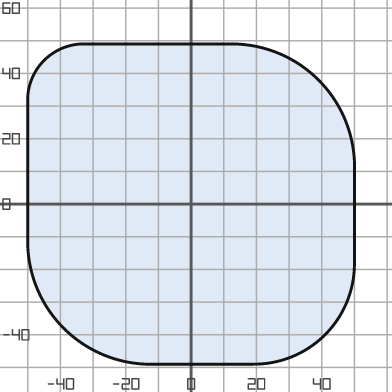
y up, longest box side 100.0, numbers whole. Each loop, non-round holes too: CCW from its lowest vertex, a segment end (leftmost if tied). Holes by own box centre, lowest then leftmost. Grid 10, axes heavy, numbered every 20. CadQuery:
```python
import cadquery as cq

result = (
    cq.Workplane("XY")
    .moveTo(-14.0, -49.0)
    .lineTo(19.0, -49.0)
    .threePointArc((41.0, -40.0), (50.0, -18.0))
    .lineTo(50.0, 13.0)
    .threePointArc((39.0, 38.0), (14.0, 49.0))
    .lineTo(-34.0, 49.0)
    .threePointArc((-45.0, 44.0), (-50.0, 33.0))
    .lineTo(-50.0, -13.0)
    .threePointArc((-39.0, -38.0), (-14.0, -49.0))
    .close()
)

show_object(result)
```